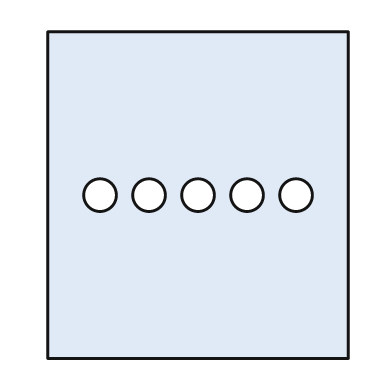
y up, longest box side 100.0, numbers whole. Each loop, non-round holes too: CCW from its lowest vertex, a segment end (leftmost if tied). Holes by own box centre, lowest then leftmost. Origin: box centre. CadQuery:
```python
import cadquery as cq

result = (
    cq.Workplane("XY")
    .moveTo(-46.0, -50.0)
    .lineTo(46.0, -50.0)
    .lineTo(46.0, 50.0)
    .lineTo(-46.0, 50.0)
    .close()
    .moveTo(-30.0, 0.0)
    .circle(5.0)
    .moveTo(-15.0, 0.0)
    .circle(5.0)
    .moveTo(0.0, 0.0)
    .circle(5.0)
    .moveTo(15.0, 0.0)
    .circle(5.0)
    .moveTo(30.0, 0.0)
    .circle(5.0)
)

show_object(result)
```